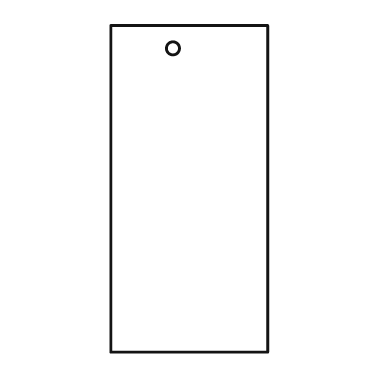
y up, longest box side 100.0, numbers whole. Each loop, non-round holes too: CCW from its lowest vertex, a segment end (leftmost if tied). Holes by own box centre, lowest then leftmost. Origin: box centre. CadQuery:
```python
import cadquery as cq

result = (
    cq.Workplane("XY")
    .moveTo(-24.0, -50.0)
    .lineTo(24.0, -50.0)
    .lineTo(24.0, 50.0)
    .lineTo(-24.0, 50.0)
    .close()
    .moveTo(-5.0, 43.0)
    .circle(2.0)
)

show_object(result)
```